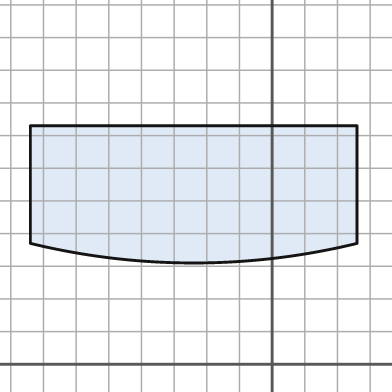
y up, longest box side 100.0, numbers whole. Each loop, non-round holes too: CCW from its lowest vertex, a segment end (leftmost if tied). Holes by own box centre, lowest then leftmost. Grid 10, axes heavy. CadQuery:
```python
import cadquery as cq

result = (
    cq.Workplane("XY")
    .moveTo(-74.0, 37.0)
    .threePointArc((-24.0, 31.0), (26.0, 37.0))
    .lineTo(26.0, 73.0)
    .lineTo(-74.0, 73.0)
    .close()
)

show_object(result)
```